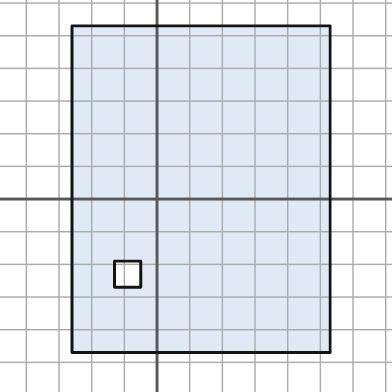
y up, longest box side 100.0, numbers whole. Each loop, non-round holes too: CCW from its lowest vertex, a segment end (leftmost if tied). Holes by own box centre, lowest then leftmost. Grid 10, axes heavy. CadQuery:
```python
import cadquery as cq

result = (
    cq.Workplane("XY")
    .moveTo(-26.0, -47.0)
    .lineTo(53.0, -47.0)
    .lineTo(53.0, 53.0)
    .lineTo(-26.0, 53.0)
    .close()
    .moveTo(-13.0, -27.0)
    .lineTo(-5.0, -27.0)
    .lineTo(-5.0, -19.0)
    .lineTo(-13.0, -19.0)
    .close()
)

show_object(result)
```